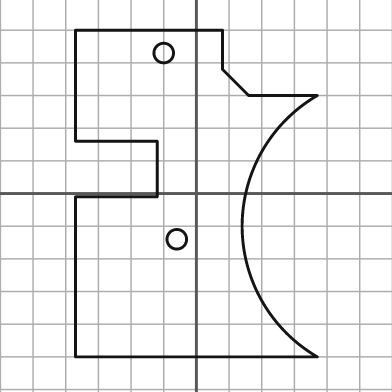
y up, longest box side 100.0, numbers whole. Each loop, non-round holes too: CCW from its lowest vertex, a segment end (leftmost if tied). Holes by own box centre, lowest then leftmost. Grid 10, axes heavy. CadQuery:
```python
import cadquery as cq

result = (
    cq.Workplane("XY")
    .moveTo(-37.0, -50.0)
    .lineTo(37.0, -50.0)
    .threePointArc((14.0, -10.0), (37.0, 30.0))
    .lineTo(16.0, 30.0)
    .lineTo(8.0, 38.0)
    .lineTo(8.0, 50.0)
    .lineTo(-37.0, 50.0)
    .lineTo(-37.0, 16.0)
    .lineTo(-12.0, 16.0)
    .lineTo(-12.0, -1.0)
    .lineTo(-37.0, -1.0)
    .close()
    .moveTo(-6.0, -14.0)
    .circle(3.0)
    .moveTo(-10.0, 43.0)
    .circle(3.0)
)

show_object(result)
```